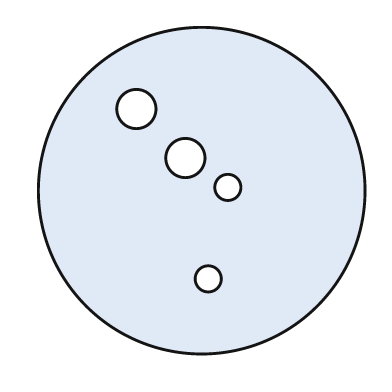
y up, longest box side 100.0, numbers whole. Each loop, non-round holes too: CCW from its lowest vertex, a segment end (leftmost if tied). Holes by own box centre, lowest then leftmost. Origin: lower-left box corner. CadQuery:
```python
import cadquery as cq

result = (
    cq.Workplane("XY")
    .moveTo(50.0, 50.0)
    .circle(50.0)
    .moveTo(52.0, 23.0)
    .circle(4.0)
    .moveTo(58.0, 51.0)
    .circle(4.0)
    .moveTo(45.0, 60.0)
    .circle(6.0)
    .moveTo(30.0, 75.0)
    .circle(6.0)
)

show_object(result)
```